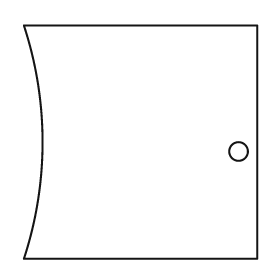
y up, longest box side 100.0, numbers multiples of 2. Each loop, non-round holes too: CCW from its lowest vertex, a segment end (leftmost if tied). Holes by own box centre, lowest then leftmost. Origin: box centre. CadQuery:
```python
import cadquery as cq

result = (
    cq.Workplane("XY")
    .moveTo(-50.0, -50.0)
    .lineTo(50.0, -50.0)
    .lineTo(50.0, 50.0)
    .lineTo(-50.0, 50.0)
    .threePointArc((-42.0, 0.0), (-50.0, -50.0))
    .close()
    .moveTo(42.0, -4.0)
    .circle(4.0)
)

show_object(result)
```